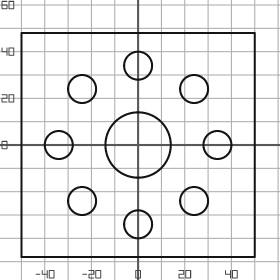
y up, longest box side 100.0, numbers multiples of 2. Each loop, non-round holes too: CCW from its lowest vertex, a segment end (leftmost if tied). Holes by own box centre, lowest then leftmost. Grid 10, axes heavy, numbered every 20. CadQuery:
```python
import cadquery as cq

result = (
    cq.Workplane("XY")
    .moveTo(-50.0, -48.0)
    .lineTo(50.0, -48.0)
    .lineTo(50.0, 48.0)
    .lineTo(-50.0, 48.0)
    .close()
    .moveTo(0.0, -34.0)
    .circle(6.0)
    .moveTo(-24.0, -24.0)
    .circle(6.0)
    .moveTo(24.0, -24.0)
    .circle(6.0)
    .moveTo(-34.0, 0.0)
    .circle(6.0)
    .moveTo(0.0, 0.0)
    .circle(14.0)
    .moveTo(34.0, 0.0)
    .circle(6.0)
    .moveTo(-24.0, 24.0)
    .circle(6.0)
    .moveTo(24.0, 24.0)
    .circle(6.0)
    .moveTo(0.0, 34.0)
    .circle(6.0)
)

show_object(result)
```